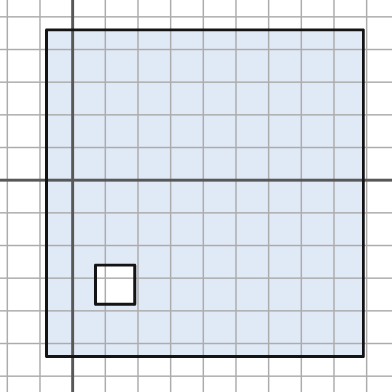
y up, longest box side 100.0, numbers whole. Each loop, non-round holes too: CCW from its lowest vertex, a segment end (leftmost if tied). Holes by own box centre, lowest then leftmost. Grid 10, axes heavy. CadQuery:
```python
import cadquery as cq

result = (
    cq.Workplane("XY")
    .moveTo(-8.0, -54.0)
    .lineTo(89.0, -54.0)
    .lineTo(89.0, 46.0)
    .lineTo(-8.0, 46.0)
    .close()
    .moveTo(7.0, -38.0)
    .lineTo(19.0, -38.0)
    .lineTo(19.0, -26.0)
    .lineTo(7.0, -26.0)
    .close()
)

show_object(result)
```